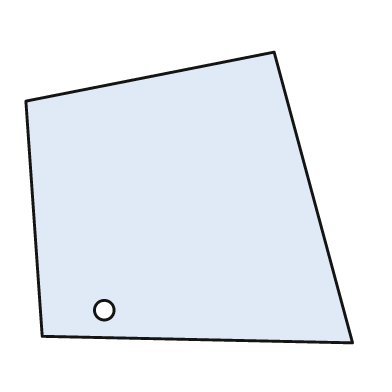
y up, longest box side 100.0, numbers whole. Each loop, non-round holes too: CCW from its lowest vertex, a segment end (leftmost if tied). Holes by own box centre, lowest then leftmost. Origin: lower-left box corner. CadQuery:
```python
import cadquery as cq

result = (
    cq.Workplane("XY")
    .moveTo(100.0, 0.0)
    .lineTo(76.0, 89.0)
    .lineTo(0.0, 74.0)
    .lineTo(5.0, 2.0)
    .close()
    .moveTo(24.0, 10.0)
    .circle(3.0)
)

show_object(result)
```